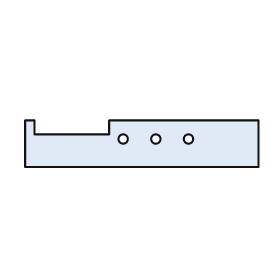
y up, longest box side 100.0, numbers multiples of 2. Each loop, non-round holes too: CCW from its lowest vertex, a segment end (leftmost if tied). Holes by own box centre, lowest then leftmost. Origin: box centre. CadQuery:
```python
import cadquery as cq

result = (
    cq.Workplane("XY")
    .moveTo(-50.0, -10.0)
    .lineTo(50.0, -10.0)
    .lineTo(50.0, 10.0)
    .lineTo(-14.0, 10.0)
    .lineTo(-14.0, 4.0)
    .lineTo(-46.0, 4.0)
    .lineTo(-46.0, 10.0)
    .lineTo(-50.0, 10.0)
    .close()
    .moveTo(-8.0, 2.0)
    .circle(2.0)
    .moveTo(6.0, 2.0)
    .circle(2.0)
    .moveTo(20.0, 2.0)
    .circle(2.0)
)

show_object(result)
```